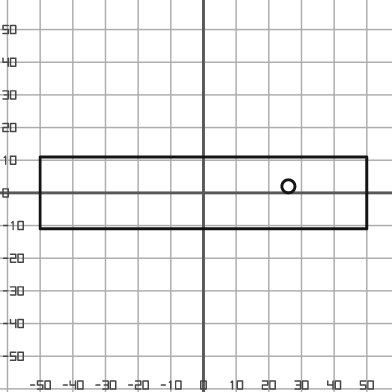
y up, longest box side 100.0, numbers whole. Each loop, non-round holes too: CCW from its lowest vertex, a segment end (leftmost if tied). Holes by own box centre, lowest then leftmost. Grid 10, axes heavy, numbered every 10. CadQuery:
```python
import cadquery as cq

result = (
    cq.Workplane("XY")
    .moveTo(-50.0, -11.0)
    .lineTo(50.0, -11.0)
    .lineTo(50.0, 11.0)
    .lineTo(-50.0, 11.0)
    .close()
    .moveTo(26.0, 2.0)
    .circle(2.0)
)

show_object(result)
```